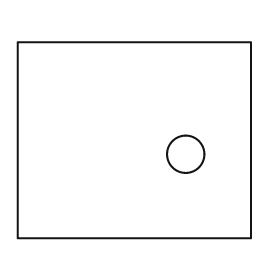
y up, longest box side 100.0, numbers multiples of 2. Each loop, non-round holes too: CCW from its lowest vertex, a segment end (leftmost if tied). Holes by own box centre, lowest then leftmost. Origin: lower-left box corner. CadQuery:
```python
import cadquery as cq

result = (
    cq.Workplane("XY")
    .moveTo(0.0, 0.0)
    .lineTo(100.0, 0.0)
    .lineTo(100.0, 84.0)
    .lineTo(0.0, 84.0)
    .close()
    .moveTo(72.0, 36.0)
    .circle(8.0)
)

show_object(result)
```